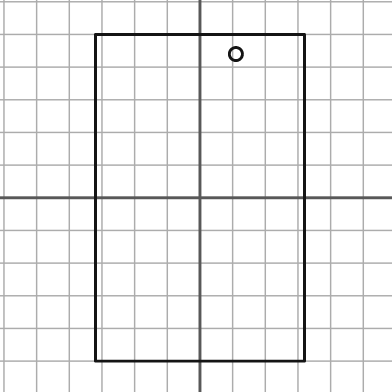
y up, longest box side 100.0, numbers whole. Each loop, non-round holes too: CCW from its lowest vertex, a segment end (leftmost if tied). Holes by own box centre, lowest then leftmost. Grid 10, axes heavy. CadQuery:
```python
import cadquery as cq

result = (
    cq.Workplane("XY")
    .moveTo(-32.0, -50.0)
    .lineTo(32.0, -50.0)
    .lineTo(32.0, 50.0)
    .lineTo(-32.0, 50.0)
    .close()
    .moveTo(11.0, 44.0)
    .circle(2.0)
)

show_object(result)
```